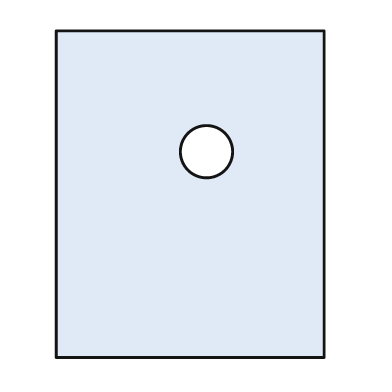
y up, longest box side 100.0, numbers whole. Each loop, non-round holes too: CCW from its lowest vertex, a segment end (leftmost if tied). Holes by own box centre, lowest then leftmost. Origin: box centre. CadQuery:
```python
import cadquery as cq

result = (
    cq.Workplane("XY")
    .moveTo(-41.0, -50.0)
    .lineTo(41.0, -50.0)
    .lineTo(41.0, 50.0)
    .lineTo(-41.0, 50.0)
    .close()
    .moveTo(5.0, 13.0)
    .circle(8.0)
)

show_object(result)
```